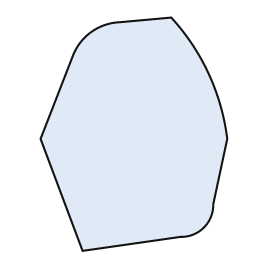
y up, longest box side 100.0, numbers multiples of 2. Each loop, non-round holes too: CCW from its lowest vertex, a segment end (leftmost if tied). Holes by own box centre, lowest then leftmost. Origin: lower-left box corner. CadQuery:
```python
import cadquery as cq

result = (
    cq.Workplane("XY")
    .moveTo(18.0, 0.0)
    .lineTo(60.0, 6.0)
    .threePointArc((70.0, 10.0), (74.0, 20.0))
    .lineTo(80.0, 48.0)
    .threePointArc((72.0, 76.0), (56.0, 100.0))
    .lineTo(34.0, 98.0)
    .threePointArc((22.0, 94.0), (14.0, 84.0))
    .lineTo(0.0, 48.0)
    .close()
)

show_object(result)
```